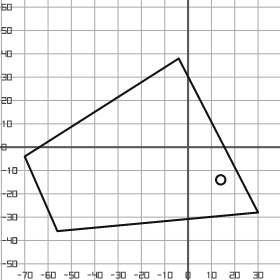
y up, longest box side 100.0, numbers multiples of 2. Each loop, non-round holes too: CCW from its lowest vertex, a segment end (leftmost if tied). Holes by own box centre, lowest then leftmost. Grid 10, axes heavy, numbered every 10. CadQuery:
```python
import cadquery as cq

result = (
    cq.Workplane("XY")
    .moveTo(-56.0, -36.0)
    .lineTo(30.0, -28.0)
    .lineTo(-4.0, 38.0)
    .lineTo(-70.0, -4.0)
    .close()
    .moveTo(14.0, -14.0)
    .circle(2.0)
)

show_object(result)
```